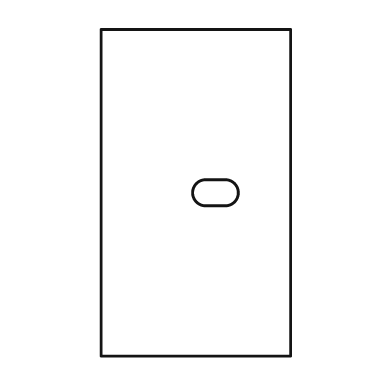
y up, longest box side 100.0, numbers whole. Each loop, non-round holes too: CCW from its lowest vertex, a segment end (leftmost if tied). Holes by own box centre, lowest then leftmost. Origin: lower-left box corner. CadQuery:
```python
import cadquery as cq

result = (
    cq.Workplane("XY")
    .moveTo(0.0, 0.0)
    .lineTo(58.0, 0.0)
    .lineTo(58.0, 100.0)
    .lineTo(0.0, 100.0)
    .close()
    .moveTo(32.0, 46.0)
    .lineTo(38.0, 46.0)
    .threePointArc((42.0, 50.0), (38.0, 54.0))
    .lineTo(32.0, 54.0)
    .threePointArc((28.0, 50.0), (32.0, 46.0))
    .close()
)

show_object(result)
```